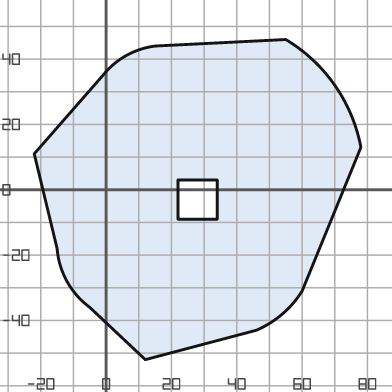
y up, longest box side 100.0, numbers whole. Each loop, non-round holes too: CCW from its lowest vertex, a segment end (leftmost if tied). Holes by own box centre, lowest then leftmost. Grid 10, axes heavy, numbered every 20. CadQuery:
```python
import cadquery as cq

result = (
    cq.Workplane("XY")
    .moveTo(12.0, -52.0)
    .lineTo(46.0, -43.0)
    .threePointArc((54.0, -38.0), (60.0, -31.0))
    .lineTo(78.0, 13.0)
    .threePointArc((70.0, 32.0), (55.0, 46.0))
    .lineTo(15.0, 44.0)
    .threePointArc((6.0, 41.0), (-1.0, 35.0))
    .lineTo(-22.0, 11.0)
    .lineTo(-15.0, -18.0)
    .threePointArc((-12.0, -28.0), (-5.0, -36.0))
    .close()
    .moveTo(22.0, -9.0)
    .lineTo(34.0, -9.0)
    .lineTo(34.0, 3.0)
    .lineTo(22.0, 3.0)
    .close()
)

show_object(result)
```